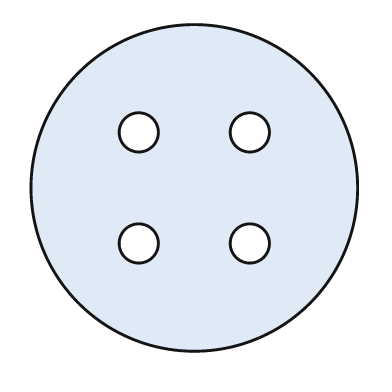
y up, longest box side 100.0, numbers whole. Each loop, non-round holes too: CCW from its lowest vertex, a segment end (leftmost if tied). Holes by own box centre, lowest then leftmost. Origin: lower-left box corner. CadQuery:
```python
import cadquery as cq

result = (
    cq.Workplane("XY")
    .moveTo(50.0, 50.0)
    .circle(50.0)
    .moveTo(33.0, 33.0)
    .circle(6.0)
    .moveTo(67.0, 33.0)
    .circle(6.0)
    .moveTo(33.0, 67.0)
    .circle(6.0)
    .moveTo(67.0, 67.0)
    .circle(6.0)
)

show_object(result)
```